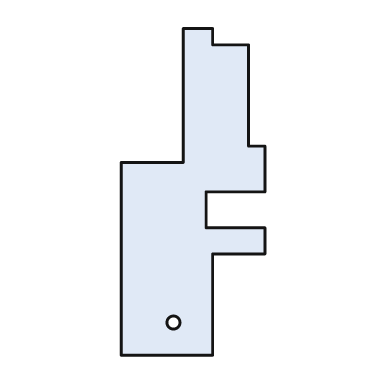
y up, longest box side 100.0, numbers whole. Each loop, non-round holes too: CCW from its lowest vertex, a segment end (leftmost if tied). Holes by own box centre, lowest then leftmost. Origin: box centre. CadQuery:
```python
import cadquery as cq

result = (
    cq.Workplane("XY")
    .moveTo(-22.0, -50.0)
    .lineTo(6.0, -50.0)
    .lineTo(6.0, -19.0)
    .lineTo(22.0, -19.0)
    .lineTo(22.0, -11.0)
    .lineTo(4.0, -11.0)
    .lineTo(4.0, 0.0)
    .lineTo(22.0, 0.0)
    .lineTo(22.0, 14.0)
    .lineTo(17.0, 14.0)
    .lineTo(17.0, 45.0)
    .lineTo(6.0, 45.0)
    .lineTo(6.0, 50.0)
    .lineTo(-3.0, 50.0)
    .lineTo(-3.0, 9.0)
    .lineTo(-22.0, 9.0)
    .close()
    .moveTo(-6.0, -40.0)
    .circle(2.0)
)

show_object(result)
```